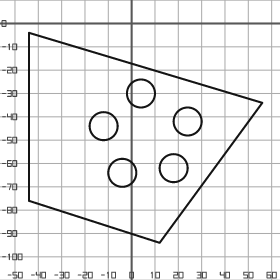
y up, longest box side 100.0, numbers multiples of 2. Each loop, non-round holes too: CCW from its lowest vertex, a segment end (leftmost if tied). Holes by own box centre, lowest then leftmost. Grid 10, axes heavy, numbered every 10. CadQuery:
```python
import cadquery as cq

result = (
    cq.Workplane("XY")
    .moveTo(12.0, -94.0)
    .lineTo(56.0, -34.0)
    .lineTo(-44.0, -4.0)
    .lineTo(-44.0, -76.0)
    .close()
    .moveTo(-4.0, -64.0)
    .circle(6.0)
    .moveTo(18.0, -62.0)
    .circle(6.0)
    .moveTo(-12.0, -44.0)
    .circle(6.0)
    .moveTo(24.0, -42.0)
    .circle(6.0)
    .moveTo(4.0, -30.0)
    .circle(6.0)
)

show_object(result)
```